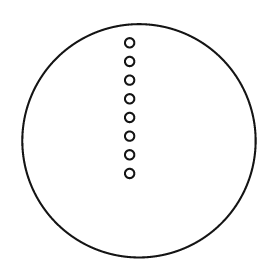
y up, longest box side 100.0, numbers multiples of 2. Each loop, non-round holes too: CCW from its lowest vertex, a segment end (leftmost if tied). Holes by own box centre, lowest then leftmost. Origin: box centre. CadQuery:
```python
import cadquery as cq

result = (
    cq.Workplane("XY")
    .moveTo(0.0, 0.0)
    .circle(50.0)
    .moveTo(-4.0, -14.0)
    .circle(2.0)
    .moveTo(-4.0, -6.0)
    .circle(2.0)
    .moveTo(-4.0, 2.0)
    .circle(2.0)
    .moveTo(-4.0, 10.0)
    .circle(2.0)
    .moveTo(-4.0, 18.0)
    .circle(2.0)
    .moveTo(-4.0, 26.0)
    .circle(2.0)
    .moveTo(-4.0, 34.0)
    .circle(2.0)
    .moveTo(-4.0, 42.0)
    .circle(2.0)
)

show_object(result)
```